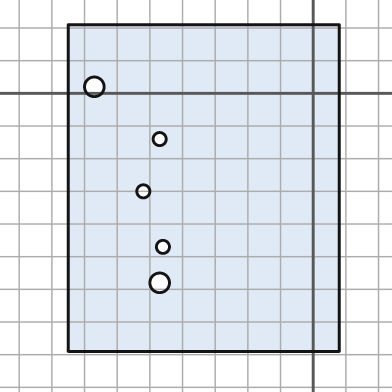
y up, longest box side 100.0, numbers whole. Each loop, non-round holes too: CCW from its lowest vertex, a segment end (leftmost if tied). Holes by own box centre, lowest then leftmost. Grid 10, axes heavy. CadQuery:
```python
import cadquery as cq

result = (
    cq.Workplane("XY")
    .moveTo(-75.0, -79.0)
    .lineTo(8.0, -79.0)
    .lineTo(8.0, 21.0)
    .lineTo(-75.0, 21.0)
    .close()
    .moveTo(-47.0, -58.0)
    .circle(3.0)
    .moveTo(-46.0, -47.0)
    .circle(2.0)
    .moveTo(-52.0, -30.0)
    .circle(2.0)
    .moveTo(-47.0, -14.0)
    .circle(2.0)
    .moveTo(-67.0, 2.0)
    .circle(3.0)
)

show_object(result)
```